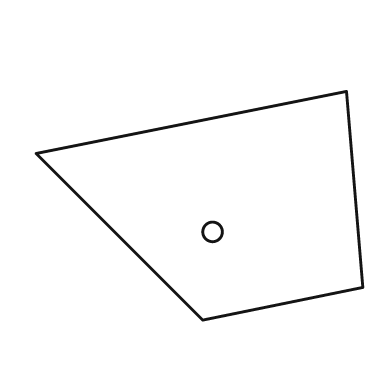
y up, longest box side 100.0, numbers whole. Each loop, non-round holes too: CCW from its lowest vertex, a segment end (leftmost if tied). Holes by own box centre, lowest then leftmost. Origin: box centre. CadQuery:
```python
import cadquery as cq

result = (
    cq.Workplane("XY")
    .moveTo(1.0, -35.0)
    .lineTo(50.0, -25.0)
    .lineTo(45.0, 35.0)
    .lineTo(-50.0, 16.0)
    .close()
    .moveTo(4.0, -8.0)
    .circle(3.0)
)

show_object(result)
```